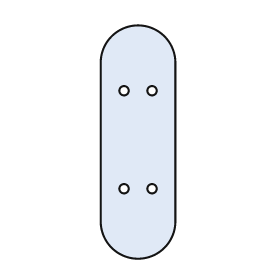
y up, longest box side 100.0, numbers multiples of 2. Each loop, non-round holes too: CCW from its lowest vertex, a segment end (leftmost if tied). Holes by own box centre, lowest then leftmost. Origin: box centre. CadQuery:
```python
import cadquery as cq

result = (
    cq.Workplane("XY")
    .moveTo(-16.0, -34.0)
    .threePointArc((0.0, -50.0), (16.0, -34.0))
    .lineTo(16.0, 34.0)
    .threePointArc((0.0, 50.0), (-16.0, 34.0))
    .close()
    .moveTo(-6.0, -20.0)
    .circle(2.0)
    .moveTo(6.0, -20.0)
    .circle(2.0)
    .moveTo(-6.0, 22.0)
    .circle(2.0)
    .moveTo(6.0, 22.0)
    .circle(2.0)
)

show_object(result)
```